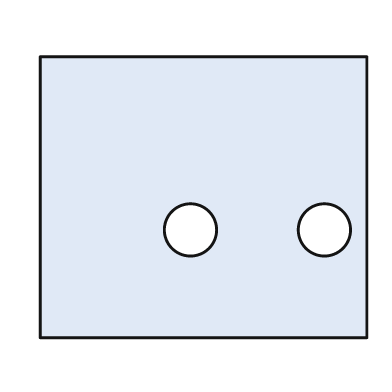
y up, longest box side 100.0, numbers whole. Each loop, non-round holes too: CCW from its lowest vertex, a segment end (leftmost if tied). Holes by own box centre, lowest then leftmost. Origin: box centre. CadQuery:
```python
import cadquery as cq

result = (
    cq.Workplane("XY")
    .moveTo(-50.0, -43.0)
    .lineTo(50.0, -43.0)
    .lineTo(50.0, 43.0)
    .lineTo(-50.0, 43.0)
    .close()
    .moveTo(-4.0, -10.0)
    .circle(8.0)
    .moveTo(37.0, -10.0)
    .circle(8.0)
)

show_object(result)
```